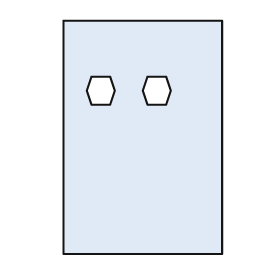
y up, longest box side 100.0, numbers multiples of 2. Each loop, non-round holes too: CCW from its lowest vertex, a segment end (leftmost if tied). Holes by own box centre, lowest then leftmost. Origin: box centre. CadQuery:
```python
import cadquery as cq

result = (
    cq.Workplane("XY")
    .moveTo(-34.0, -50.0)
    .lineTo(34.0, -50.0)
    .lineTo(34.0, 50.0)
    .lineTo(-34.0, 50.0)
    .close()
    .moveTo(-22.0, 14.0)
    .lineTo(-14.0, 14.0)
    .lineTo(-12.0, 20.0)
    .lineTo(-14.0, 26.0)
    .lineTo(-22.0, 26.0)
    .lineTo(-24.0, 20.0)
    .close()
    .moveTo(2.0, 14.0)
    .lineTo(10.0, 14.0)
    .lineTo(12.0, 20.0)
    .lineTo(10.0, 26.0)
    .lineTo(2.0, 26.0)
    .lineTo(0.0, 20.0)
    .close()
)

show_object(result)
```